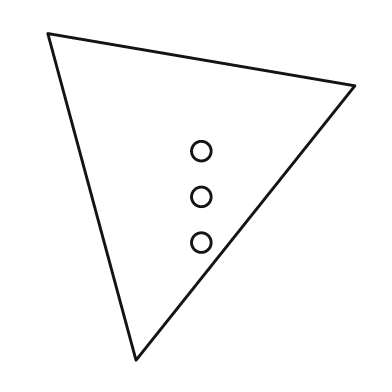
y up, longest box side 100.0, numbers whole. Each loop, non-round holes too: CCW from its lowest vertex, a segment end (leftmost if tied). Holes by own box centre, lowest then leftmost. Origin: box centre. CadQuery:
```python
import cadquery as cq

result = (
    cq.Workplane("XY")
    .moveTo(-20.0, -50.0)
    .lineTo(47.0, 34.0)
    .lineTo(-47.0, 50.0)
    .close()
    .moveTo(0.0, -14.0)
    .circle(3.0)
    .moveTo(0.0, 0.0)
    .circle(3.0)
    .moveTo(0.0, 14.0)
    .circle(3.0)
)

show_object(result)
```